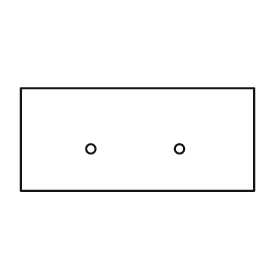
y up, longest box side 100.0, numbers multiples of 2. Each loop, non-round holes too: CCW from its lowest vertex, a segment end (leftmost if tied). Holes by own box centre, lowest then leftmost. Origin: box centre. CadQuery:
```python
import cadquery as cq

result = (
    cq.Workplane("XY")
    .moveTo(-50.0, -22.0)
    .lineTo(50.0, -22.0)
    .lineTo(50.0, 22.0)
    .lineTo(-50.0, 22.0)
    .close()
    .moveTo(-20.0, -4.0)
    .circle(2.0)
    .moveTo(18.0, -4.0)
    .circle(2.0)
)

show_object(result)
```